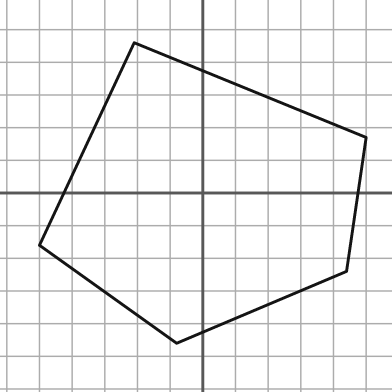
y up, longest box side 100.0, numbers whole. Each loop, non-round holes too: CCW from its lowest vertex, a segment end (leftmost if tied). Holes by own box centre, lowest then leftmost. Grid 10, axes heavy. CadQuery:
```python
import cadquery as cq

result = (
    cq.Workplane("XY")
    .moveTo(-8.0, -46.0)
    .lineTo(44.0, -24.0)
    .lineTo(50.0, 17.0)
    .lineTo(-21.0, 46.0)
    .lineTo(-50.0, -16.0)
    .close()
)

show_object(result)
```